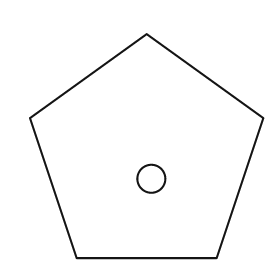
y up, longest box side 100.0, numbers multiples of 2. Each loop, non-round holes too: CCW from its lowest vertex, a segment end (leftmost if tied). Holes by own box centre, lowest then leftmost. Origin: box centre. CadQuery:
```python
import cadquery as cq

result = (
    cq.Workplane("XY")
    .moveTo(-30.0, -48.0)
    .lineTo(30.0, -48.0)
    .lineTo(50.0, 12.0)
    .lineTo(0.0, 48.0)
    .lineTo(-50.0, 12.0)
    .close()
    .moveTo(2.0, -14.0)
    .circle(6.0)
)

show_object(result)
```